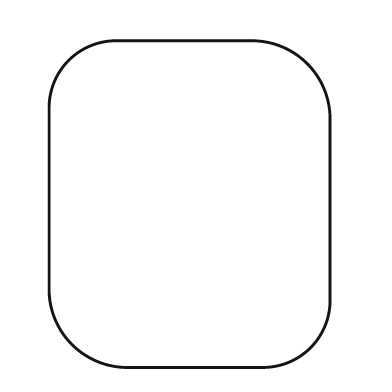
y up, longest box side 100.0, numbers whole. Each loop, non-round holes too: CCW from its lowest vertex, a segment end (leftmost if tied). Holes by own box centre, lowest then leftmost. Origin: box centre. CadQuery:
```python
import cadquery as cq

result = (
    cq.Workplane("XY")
    .moveTo(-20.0, -50.0)
    .lineTo(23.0, -50.0)
    .threePointArc((37.0, -44.0), (43.0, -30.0))
    .lineTo(43.0, 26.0)
    .threePointArc((36.0, 43.0), (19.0, 50.0))
    .lineTo(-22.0, 50.0)
    .threePointArc((-37.0, 44.0), (-43.0, 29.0))
    .lineTo(-43.0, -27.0)
    .threePointArc((-36.0, -43.0), (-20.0, -50.0))
    .close()
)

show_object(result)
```